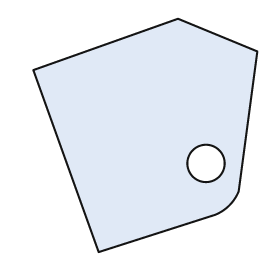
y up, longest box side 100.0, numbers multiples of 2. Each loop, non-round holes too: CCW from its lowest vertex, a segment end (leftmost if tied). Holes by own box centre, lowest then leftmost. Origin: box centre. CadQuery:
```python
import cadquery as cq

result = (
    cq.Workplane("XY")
    .moveTo(-20.0, -50.0)
    .lineTo(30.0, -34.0)
    .threePointArc((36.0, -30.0), (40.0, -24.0))
    .lineTo(48.0, 36.0)
    .lineTo(14.0, 50.0)
    .lineTo(-48.0, 28.0)
    .close()
    .moveTo(26.0, -12.0)
    .circle(8.0)
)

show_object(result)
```